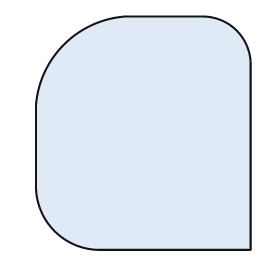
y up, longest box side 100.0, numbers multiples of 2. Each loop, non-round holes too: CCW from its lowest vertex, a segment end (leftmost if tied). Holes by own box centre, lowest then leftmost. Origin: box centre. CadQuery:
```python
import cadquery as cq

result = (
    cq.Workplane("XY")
    .moveTo(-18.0, -50.0)
    .lineTo(46.0, -50.0)
    .lineTo(46.0, 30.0)
    .threePointArc((40.0, 44.0), (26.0, 50.0))
    .lineTo(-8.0, 50.0)
    .threePointArc((-34.0, 38.0), (-46.0, 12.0))
    .lineTo(-46.0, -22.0)
    .threePointArc((-38.0, -42.0), (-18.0, -50.0))
    .close()
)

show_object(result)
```